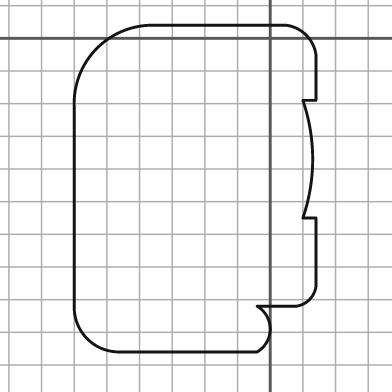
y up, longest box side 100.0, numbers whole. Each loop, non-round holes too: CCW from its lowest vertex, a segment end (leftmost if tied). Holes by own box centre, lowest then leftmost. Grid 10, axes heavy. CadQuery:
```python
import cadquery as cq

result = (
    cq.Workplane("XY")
    .moveTo(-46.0, -96.0)
    .lineTo(-4.0, -96.0)
    .threePointArc((0.0, -89.0), (-4.0, -82.0))
    .lineTo(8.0, -82.0)
    .threePointArc((12.0, -80.0), (14.0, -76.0))
    .lineTo(14.0, -55.0)
    .lineTo(10.0, -55.0)
    .threePointArc((13.0, -37.0), (10.0, -19.0))
    .lineTo(14.0, -19.0)
    .lineTo(14.0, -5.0)
    .threePointArc((11.0, 1.0), (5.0, 4.0))
    .lineTo(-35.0, 4.0)
    .threePointArc((-53.0, -3.0), (-60.0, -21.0))
    .lineTo(-60.0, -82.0)
    .threePointArc((-56.0, -92.0), (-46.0, -96.0))
    .close()
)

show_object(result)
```